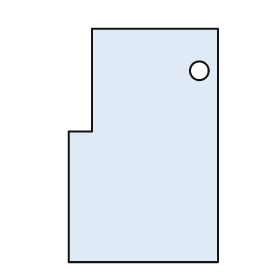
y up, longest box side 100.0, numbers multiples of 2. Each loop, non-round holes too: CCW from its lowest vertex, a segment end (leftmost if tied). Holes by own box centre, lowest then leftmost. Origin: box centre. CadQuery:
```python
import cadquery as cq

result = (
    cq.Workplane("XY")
    .moveTo(-32.0, -50.0)
    .lineTo(32.0, -50.0)
    .lineTo(32.0, 50.0)
    .lineTo(-22.0, 50.0)
    .lineTo(-22.0, 6.0)
    .lineTo(-32.0, 6.0)
    .close()
    .moveTo(24.0, 32.0)
    .circle(4.0)
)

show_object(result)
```